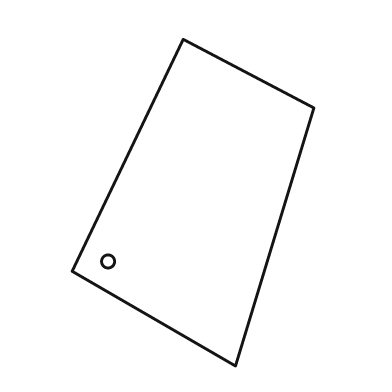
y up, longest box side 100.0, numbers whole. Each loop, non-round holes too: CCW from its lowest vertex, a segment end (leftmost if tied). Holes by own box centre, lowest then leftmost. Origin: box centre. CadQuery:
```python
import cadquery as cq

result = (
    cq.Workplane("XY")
    .moveTo(13.0, -50.0)
    .lineTo(37.0, 29.0)
    .lineTo(-3.0, 50.0)
    .lineTo(-37.0, -21.0)
    .close()
    .moveTo(-26.0, -18.0)
    .circle(2.0)
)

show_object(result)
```